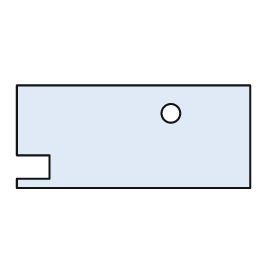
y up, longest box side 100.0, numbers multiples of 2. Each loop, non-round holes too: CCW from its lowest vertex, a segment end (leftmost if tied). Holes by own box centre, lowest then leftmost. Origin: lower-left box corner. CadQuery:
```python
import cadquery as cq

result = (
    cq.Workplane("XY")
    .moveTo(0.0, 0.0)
    .lineTo(100.0, 0.0)
    .lineTo(100.0, 44.0)
    .lineTo(0.0, 44.0)
    .lineTo(0.0, 14.0)
    .lineTo(14.0, 14.0)
    .lineTo(14.0, 4.0)
    .lineTo(0.0, 4.0)
    .close()
    .moveTo(66.0, 32.0)
    .circle(4.0)
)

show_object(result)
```